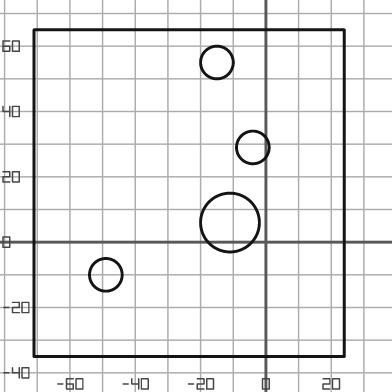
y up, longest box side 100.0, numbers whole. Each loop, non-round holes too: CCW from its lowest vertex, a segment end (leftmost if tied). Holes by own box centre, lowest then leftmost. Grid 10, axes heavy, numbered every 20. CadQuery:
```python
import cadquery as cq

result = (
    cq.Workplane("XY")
    .moveTo(-71.0, -35.0)
    .lineTo(24.0, -35.0)
    .lineTo(24.0, 65.0)
    .lineTo(-71.0, 65.0)
    .close()
    .moveTo(-49.0, -10.0)
    .circle(5.0)
    .moveTo(-11.0, 6.0)
    .circle(9.0)
    .moveTo(-4.0, 29.0)
    .circle(5.0)
    .moveTo(-15.0, 55.0)
    .circle(5.0)
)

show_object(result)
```